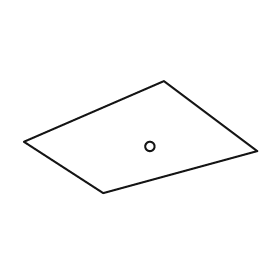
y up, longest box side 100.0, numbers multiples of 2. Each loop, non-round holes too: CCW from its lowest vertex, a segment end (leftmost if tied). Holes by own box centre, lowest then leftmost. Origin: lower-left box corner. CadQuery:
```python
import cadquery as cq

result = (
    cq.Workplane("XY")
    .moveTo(34.0, 0.0)
    .lineTo(100.0, 18.0)
    .lineTo(60.0, 48.0)
    .lineTo(0.0, 22.0)
    .close()
    .moveTo(54.0, 20.0)
    .circle(2.0)
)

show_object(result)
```